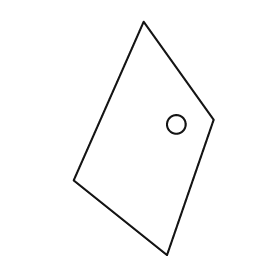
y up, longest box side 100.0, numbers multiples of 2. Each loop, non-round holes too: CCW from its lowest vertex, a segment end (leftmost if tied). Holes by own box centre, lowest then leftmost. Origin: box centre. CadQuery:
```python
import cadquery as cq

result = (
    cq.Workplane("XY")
    .moveTo(10.0, -50.0)
    .lineTo(30.0, 8.0)
    .lineTo(0.0, 50.0)
    .lineTo(-30.0, -18.0)
    .close()
    .moveTo(14.0, 6.0)
    .circle(4.0)
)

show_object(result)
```